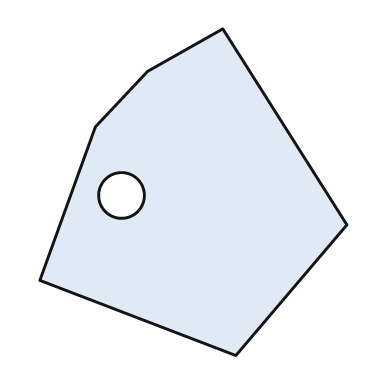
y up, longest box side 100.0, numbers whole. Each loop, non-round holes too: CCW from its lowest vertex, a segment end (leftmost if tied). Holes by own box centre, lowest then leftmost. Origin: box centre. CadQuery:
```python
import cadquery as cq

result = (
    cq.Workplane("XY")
    .moveTo(13.0, -50.0)
    .lineTo(47.0, -10.0)
    .lineTo(9.0, 50.0)
    .lineTo(-14.0, 37.0)
    .lineTo(-30.0, 20.0)
    .lineTo(-47.0, -27.0)
    .close()
    .moveTo(-22.0, -1.0)
    .circle(7.0)
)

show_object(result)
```